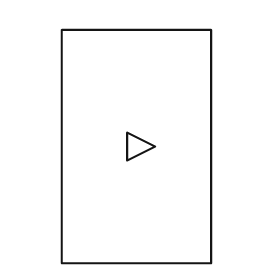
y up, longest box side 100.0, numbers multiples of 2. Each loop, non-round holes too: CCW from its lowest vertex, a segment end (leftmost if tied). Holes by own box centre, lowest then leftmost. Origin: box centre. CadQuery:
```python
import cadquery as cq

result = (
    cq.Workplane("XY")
    .moveTo(-32.0, -50.0)
    .lineTo(32.0, -50.0)
    .lineTo(32.0, 50.0)
    .lineTo(-32.0, 50.0)
    .close()
    .moveTo(-4.0, -6.0)
    .lineTo(8.0, 0.0)
    .lineTo(-4.0, 6.0)
    .close()
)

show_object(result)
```